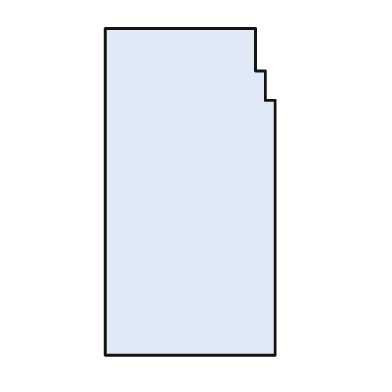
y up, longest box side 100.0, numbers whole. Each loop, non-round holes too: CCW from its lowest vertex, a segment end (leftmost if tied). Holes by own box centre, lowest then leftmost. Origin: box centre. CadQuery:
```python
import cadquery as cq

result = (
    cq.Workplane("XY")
    .moveTo(-26.0, -50.0)
    .lineTo(26.0, -50.0)
    .lineTo(26.0, 28.0)
    .lineTo(23.0, 28.0)
    .lineTo(23.0, 37.0)
    .lineTo(20.0, 37.0)
    .lineTo(20.0, 50.0)
    .lineTo(-26.0, 50.0)
    .close()
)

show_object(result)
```